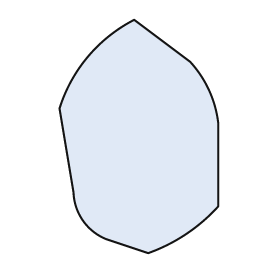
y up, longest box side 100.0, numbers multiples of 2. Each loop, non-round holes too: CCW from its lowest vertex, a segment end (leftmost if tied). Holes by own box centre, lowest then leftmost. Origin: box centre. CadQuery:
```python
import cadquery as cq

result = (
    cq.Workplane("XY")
    .moveTo(4.0, -50.0)
    .threePointArc((20.0, -42.0), (34.0, -30.0))
    .lineTo(34.0, 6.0)
    .threePointArc((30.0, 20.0), (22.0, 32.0))
    .lineTo(-2.0, 50.0)
    .threePointArc((-22.0, 34.0), (-34.0, 12.0))
    .lineTo(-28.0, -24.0)
    .threePointArc((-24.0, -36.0), (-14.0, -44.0))
    .close()
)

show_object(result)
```